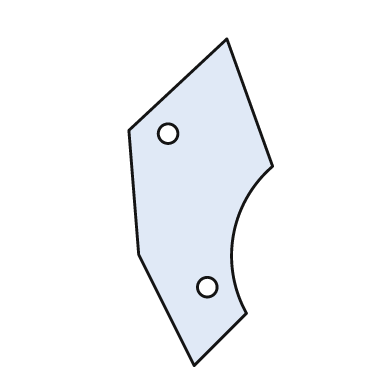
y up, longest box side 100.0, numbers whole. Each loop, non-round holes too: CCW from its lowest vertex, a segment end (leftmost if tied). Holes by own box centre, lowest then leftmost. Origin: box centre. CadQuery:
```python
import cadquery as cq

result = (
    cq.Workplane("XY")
    .moveTo(-2.0, -50.0)
    .lineTo(14.0, -34.0)
    .threePointArc((10.0, -10.0), (22.0, 11.0))
    .lineTo(8.0, 50.0)
    .lineTo(-22.0, 22.0)
    .lineTo(-19.0, -16.0)
    .close()
    .moveTo(2.0, -26.0)
    .circle(3.0)
    .moveTo(-10.0, 21.0)
    .circle(3.0)
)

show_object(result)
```